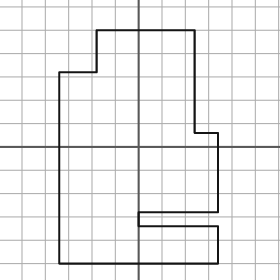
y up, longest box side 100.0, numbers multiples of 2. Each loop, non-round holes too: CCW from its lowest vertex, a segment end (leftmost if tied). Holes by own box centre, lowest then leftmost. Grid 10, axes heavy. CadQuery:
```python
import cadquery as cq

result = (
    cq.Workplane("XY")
    .moveTo(-34.0, -50.0)
    .lineTo(34.0, -50.0)
    .lineTo(34.0, -34.0)
    .lineTo(0.0, -34.0)
    .lineTo(0.0, -28.0)
    .lineTo(34.0, -28.0)
    .lineTo(34.0, 6.0)
    .lineTo(24.0, 6.0)
    .lineTo(24.0, 50.0)
    .lineTo(-18.0, 50.0)
    .lineTo(-18.0, 32.0)
    .lineTo(-34.0, 32.0)
    .close()
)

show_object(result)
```